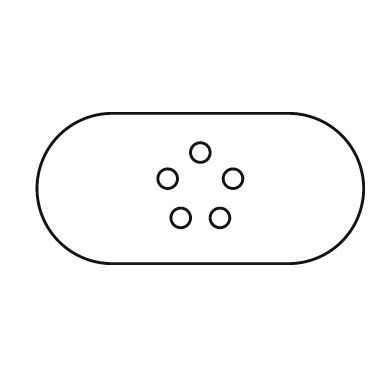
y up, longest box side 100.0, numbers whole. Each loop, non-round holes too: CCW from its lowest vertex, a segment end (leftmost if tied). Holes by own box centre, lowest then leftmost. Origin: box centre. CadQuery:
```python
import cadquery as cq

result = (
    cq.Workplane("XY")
    .moveTo(-27.0, -23.0)
    .lineTo(27.0, -23.0)
    .threePointArc((50.0, 0.0), (27.0, 23.0))
    .lineTo(-27.0, 23.0)
    .threePointArc((-50.0, 0.0), (-27.0, -23.0))
    .close()
    .moveTo(-6.0, -9.0)
    .circle(3.0)
    .moveTo(6.0, -9.0)
    .circle(3.0)
    .moveTo(-10.0, 3.0)
    .circle(3.0)
    .moveTo(10.0, 3.0)
    .circle(3.0)
    .moveTo(0.0, 11.0)
    .circle(3.0)
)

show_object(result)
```